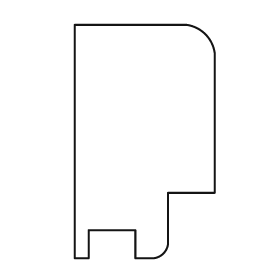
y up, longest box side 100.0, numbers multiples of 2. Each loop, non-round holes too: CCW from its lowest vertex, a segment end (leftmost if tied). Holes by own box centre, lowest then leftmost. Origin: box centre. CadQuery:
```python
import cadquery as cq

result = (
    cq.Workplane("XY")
    .moveTo(-30.0, -50.0)
    .lineTo(-24.0, -50.0)
    .lineTo(-24.0, -38.0)
    .lineTo(-4.0, -38.0)
    .lineTo(-4.0, -50.0)
    .lineTo(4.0, -50.0)
    .threePointArc((8.0, -48.0), (10.0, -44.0))
    .lineTo(10.0, -22.0)
    .lineTo(30.0, -22.0)
    .lineTo(30.0, 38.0)
    .threePointArc((26.0, 46.0), (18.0, 50.0))
    .lineTo(-30.0, 50.0)
    .close()
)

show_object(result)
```